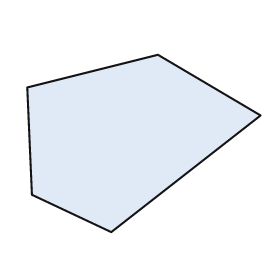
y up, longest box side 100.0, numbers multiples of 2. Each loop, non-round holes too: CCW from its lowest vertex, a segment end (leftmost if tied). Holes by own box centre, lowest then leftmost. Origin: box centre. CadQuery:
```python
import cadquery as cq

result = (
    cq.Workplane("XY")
    .moveTo(-14.0, -38.0)
    .lineTo(50.0, 12.0)
    .lineTo(6.0, 38.0)
    .lineTo(-50.0, 24.0)
    .lineTo(-48.0, -22.0)
    .close()
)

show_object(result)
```